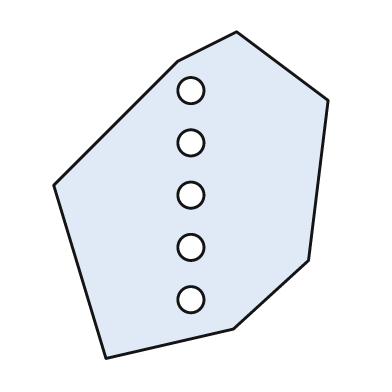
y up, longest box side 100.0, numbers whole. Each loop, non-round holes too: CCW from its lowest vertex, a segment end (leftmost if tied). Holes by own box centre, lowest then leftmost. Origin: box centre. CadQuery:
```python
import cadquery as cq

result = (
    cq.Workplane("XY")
    .moveTo(-26.0, -50.0)
    .lineTo(13.0, -41.0)
    .lineTo(36.0, -20.0)
    .lineTo(42.0, 29.0)
    .lineTo(14.0, 50.0)
    .lineTo(-4.0, 41.0)
    .lineTo(-42.0, 3.0)
    .close()
    .moveTo(0.0, -32.0)
    .circle(4.0)
    .moveTo(0.0, -16.0)
    .circle(4.0)
    .moveTo(0.0, 0.0)
    .circle(4.0)
    .moveTo(0.0, 16.0)
    .circle(4.0)
    .moveTo(0.0, 32.0)
    .circle(4.0)
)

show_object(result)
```